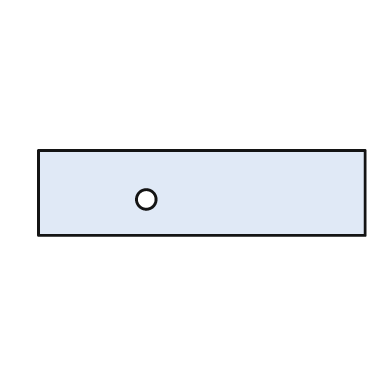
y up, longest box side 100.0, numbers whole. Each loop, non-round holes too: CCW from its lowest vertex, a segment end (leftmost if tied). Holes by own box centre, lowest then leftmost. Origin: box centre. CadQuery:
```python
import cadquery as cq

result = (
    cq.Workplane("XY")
    .moveTo(-50.0, -13.0)
    .lineTo(50.0, -13.0)
    .lineTo(50.0, 13.0)
    .lineTo(-50.0, 13.0)
    .close()
    .moveTo(-17.0, -2.0)
    .circle(3.0)
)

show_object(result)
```